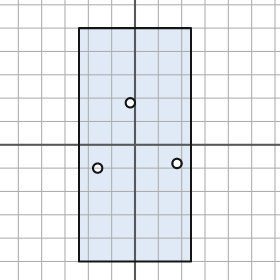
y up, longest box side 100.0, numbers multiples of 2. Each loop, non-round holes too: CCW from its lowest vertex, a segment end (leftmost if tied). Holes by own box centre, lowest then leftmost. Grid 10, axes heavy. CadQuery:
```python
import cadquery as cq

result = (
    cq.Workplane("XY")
    .moveTo(-24.0, -50.0)
    .lineTo(24.0, -50.0)
    .lineTo(24.0, 50.0)
    .lineTo(-24.0, 50.0)
    .close()
    .moveTo(-16.0, -10.0)
    .circle(2.0)
    .moveTo(18.0, -8.0)
    .circle(2.0)
    .moveTo(-2.0, 18.0)
    .circle(2.0)
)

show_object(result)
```